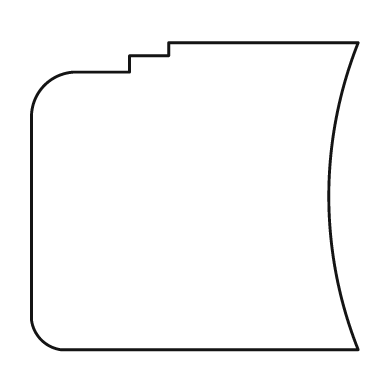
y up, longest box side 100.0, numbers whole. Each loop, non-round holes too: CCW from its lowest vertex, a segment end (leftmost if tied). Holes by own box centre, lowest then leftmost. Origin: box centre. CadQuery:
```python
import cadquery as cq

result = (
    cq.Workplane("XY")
    .moveTo(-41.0, -47.0)
    .lineTo(50.0, -47.0)
    .threePointArc((41.0, 0.0), (50.0, 47.0))
    .lineTo(-8.0, 47.0)
    .lineTo(-8.0, 43.0)
    .lineTo(-20.0, 43.0)
    .lineTo(-20.0, 38.0)
    .lineTo(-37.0, 38.0)
    .threePointArc((-46.0, 34.0), (-50.0, 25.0))
    .lineTo(-50.0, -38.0)
    .threePointArc((-47.0, -44.0), (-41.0, -47.0))
    .close()
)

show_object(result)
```